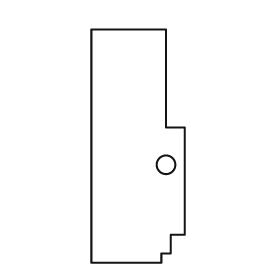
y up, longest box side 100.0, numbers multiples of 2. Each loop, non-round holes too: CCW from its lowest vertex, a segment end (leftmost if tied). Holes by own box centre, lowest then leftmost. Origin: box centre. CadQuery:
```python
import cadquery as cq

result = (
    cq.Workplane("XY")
    .moveTo(-20.0, -50.0)
    .lineTo(10.0, -50.0)
    .lineTo(10.0, -46.0)
    .lineTo(14.0, -46.0)
    .lineTo(14.0, -38.0)
    .lineTo(20.0, -38.0)
    .lineTo(20.0, 8.0)
    .lineTo(12.0, 8.0)
    .lineTo(12.0, 50.0)
    .lineTo(-20.0, 50.0)
    .close()
    .moveTo(12.0, -8.0)
    .circle(4.0)
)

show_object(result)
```